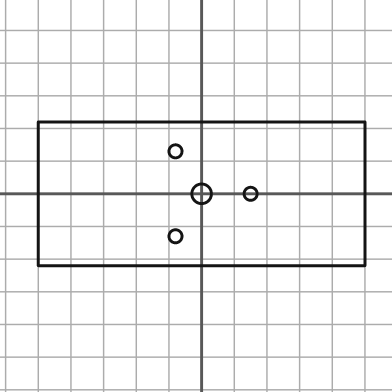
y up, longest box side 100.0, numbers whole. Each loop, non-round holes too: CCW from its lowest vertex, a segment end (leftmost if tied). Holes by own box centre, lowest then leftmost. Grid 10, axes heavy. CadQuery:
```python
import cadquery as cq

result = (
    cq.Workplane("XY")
    .moveTo(-50.0, -22.0)
    .lineTo(50.0, -22.0)
    .lineTo(50.0, 22.0)
    .lineTo(-50.0, 22.0)
    .close()
    .moveTo(-8.0, -13.0)
    .circle(2.0)
    .moveTo(0.0, 0.0)
    .circle(3.0)
    .moveTo(15.0, 0.0)
    .circle(2.0)
    .moveTo(-8.0, 13.0)
    .circle(2.0)
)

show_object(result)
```